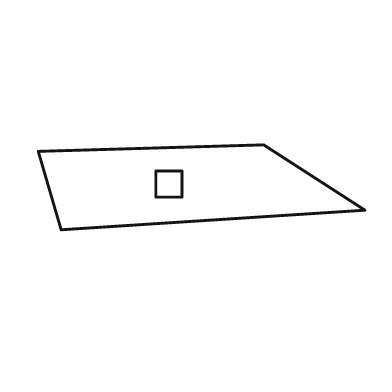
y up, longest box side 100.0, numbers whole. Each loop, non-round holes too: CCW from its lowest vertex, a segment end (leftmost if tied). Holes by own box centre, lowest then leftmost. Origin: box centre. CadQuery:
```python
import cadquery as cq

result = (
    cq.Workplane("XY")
    .moveTo(-43.0, -13.0)
    .lineTo(50.0, -7.0)
    .lineTo(19.0, 13.0)
    .lineTo(-50.0, 11.0)
    .close()
    .moveTo(-14.0, -3.0)
    .lineTo(-6.0, -3.0)
    .lineTo(-6.0, 5.0)
    .lineTo(-14.0, 5.0)
    .close()
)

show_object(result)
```